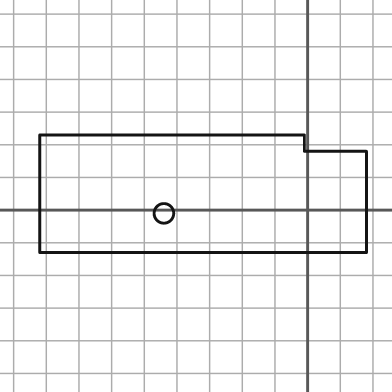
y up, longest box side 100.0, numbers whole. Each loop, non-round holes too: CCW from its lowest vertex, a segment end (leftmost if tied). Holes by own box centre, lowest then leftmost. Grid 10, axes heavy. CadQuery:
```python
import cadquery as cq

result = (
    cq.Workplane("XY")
    .moveTo(-82.0, -13.0)
    .lineTo(18.0, -13.0)
    .lineTo(18.0, 18.0)
    .lineTo(-1.0, 18.0)
    .lineTo(-1.0, 23.0)
    .lineTo(-82.0, 23.0)
    .close()
    .moveTo(-44.0, -1.0)
    .circle(3.0)
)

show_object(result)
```